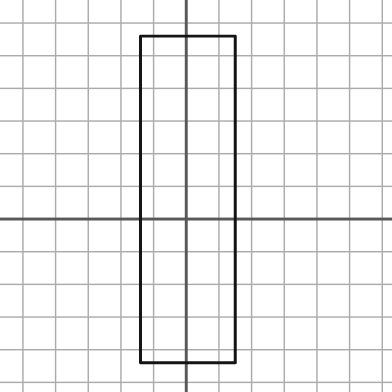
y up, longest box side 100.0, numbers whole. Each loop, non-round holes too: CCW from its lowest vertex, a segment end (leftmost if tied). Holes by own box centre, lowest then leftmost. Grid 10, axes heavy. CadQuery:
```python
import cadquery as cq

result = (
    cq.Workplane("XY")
    .moveTo(-14.0, -44.0)
    .lineTo(15.0, -44.0)
    .lineTo(15.0, 56.0)
    .lineTo(-14.0, 56.0)
    .close()
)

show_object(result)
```